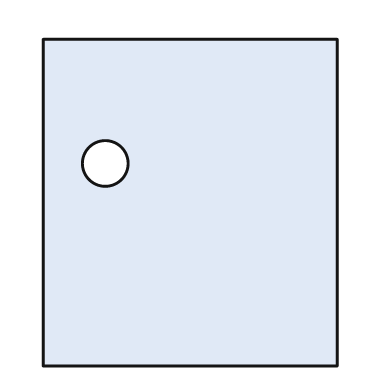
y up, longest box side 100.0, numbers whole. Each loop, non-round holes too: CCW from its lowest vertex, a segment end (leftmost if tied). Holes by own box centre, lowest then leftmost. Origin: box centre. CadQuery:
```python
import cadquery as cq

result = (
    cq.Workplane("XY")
    .moveTo(-45.0, -50.0)
    .lineTo(45.0, -50.0)
    .lineTo(45.0, 50.0)
    .lineTo(-45.0, 50.0)
    .close()
    .moveTo(-26.0, 12.0)
    .circle(7.0)
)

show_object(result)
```